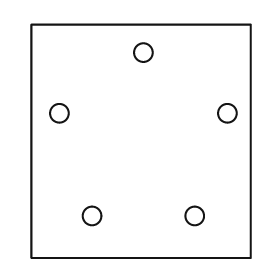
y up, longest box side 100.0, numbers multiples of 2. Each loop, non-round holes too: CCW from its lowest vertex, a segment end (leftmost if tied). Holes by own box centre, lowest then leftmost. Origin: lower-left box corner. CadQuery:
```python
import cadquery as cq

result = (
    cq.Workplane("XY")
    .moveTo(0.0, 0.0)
    .lineTo(94.0, 0.0)
    .lineTo(94.0, 100.0)
    .lineTo(0.0, 100.0)
    .close()
    .moveTo(26.0, 18.0)
    .circle(4.0)
    .moveTo(70.0, 18.0)
    .circle(4.0)
    .moveTo(12.0, 62.0)
    .circle(4.0)
    .moveTo(84.0, 62.0)
    .circle(4.0)
    .moveTo(48.0, 88.0)
    .circle(4.0)
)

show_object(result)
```